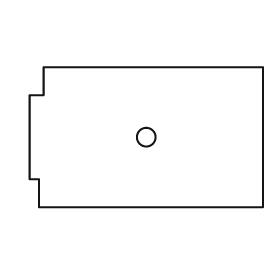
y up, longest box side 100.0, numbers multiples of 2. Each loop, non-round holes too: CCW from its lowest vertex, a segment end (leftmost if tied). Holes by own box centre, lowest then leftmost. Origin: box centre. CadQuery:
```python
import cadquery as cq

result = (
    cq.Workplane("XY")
    .moveTo(-46.0, -30.0)
    .lineTo(50.0, -30.0)
    .lineTo(50.0, 30.0)
    .lineTo(-44.0, 30.0)
    .lineTo(-44.0, 18.0)
    .lineTo(-50.0, 18.0)
    .lineTo(-50.0, -18.0)
    .lineTo(-46.0, -18.0)
    .close()
    .moveTo(0.0, 0.0)
    .circle(4.0)
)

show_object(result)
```